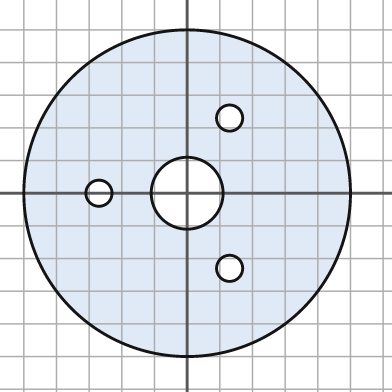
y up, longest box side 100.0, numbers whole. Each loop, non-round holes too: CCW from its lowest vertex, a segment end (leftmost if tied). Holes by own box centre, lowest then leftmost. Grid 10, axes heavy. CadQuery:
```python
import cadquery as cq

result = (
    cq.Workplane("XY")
    .moveTo(0.0, 0.0)
    .circle(50.0)
    .moveTo(13.0, -23.0)
    .circle(4.0)
    .moveTo(-27.0, 0.0)
    .circle(4.0)
    .moveTo(0.0, 0.0)
    .circle(11.0)
    .moveTo(13.0, 23.0)
    .circle(4.0)
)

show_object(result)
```